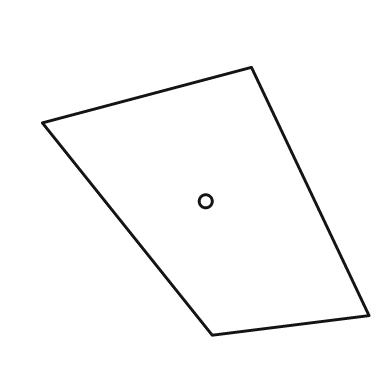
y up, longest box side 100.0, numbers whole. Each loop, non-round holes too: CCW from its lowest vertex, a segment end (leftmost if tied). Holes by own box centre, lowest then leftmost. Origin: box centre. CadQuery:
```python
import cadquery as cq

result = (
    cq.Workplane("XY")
    .moveTo(2.0, -41.0)
    .lineTo(50.0, -35.0)
    .lineTo(14.0, 41.0)
    .lineTo(-50.0, 24.0)
    .close()
    .moveTo(0.0, 0.0)
    .circle(2.0)
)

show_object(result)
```